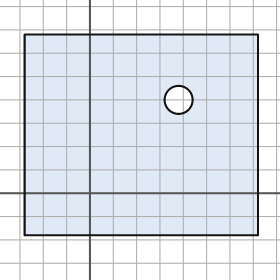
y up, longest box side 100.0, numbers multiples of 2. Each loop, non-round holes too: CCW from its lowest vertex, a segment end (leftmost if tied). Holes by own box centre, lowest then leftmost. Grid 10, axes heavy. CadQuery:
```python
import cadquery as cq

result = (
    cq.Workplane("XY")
    .moveTo(-28.0, -18.0)
    .lineTo(72.0, -18.0)
    .lineTo(72.0, 68.0)
    .lineTo(-28.0, 68.0)
    .close()
    .moveTo(38.0, 40.0)
    .circle(6.0)
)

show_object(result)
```